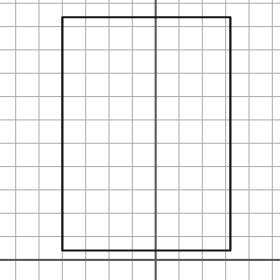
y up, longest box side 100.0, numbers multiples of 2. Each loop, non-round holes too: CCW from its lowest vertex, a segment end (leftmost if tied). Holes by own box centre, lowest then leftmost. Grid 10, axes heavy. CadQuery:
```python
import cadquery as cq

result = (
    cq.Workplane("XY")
    .moveTo(-40.0, 4.0)
    .lineTo(32.0, 4.0)
    .lineTo(32.0, 104.0)
    .lineTo(-40.0, 104.0)
    .close()
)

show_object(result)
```